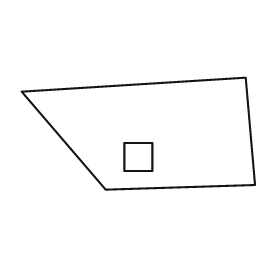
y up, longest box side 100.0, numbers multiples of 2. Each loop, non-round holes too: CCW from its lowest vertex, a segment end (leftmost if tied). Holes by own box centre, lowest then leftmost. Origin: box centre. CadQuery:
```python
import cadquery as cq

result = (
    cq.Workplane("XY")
    .moveTo(-14.0, -24.0)
    .lineTo(50.0, -22.0)
    .lineTo(46.0, 24.0)
    .lineTo(-50.0, 18.0)
    .close()
    .moveTo(-6.0, -16.0)
    .lineTo(6.0, -16.0)
    .lineTo(6.0, -4.0)
    .lineTo(-6.0, -4.0)
    .close()
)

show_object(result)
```